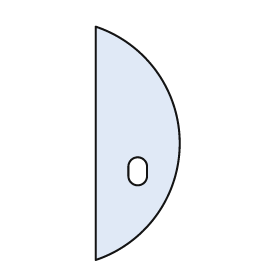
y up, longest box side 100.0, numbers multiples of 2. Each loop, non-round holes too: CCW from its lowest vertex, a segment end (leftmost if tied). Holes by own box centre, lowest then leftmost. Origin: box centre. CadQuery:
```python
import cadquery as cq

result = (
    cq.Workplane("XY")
    .moveTo(-18.0, -50.0)
    .threePointArc((18.0, 0.0), (-18.0, 50.0))
    .close()
    .moveTo(-4.0, -14.0)
    .threePointArc((0.0, -18.0), (4.0, -14.0))
    .lineTo(4.0, -10.0)
    .threePointArc((0.0, -6.0), (-4.0, -10.0))
    .close()
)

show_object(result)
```